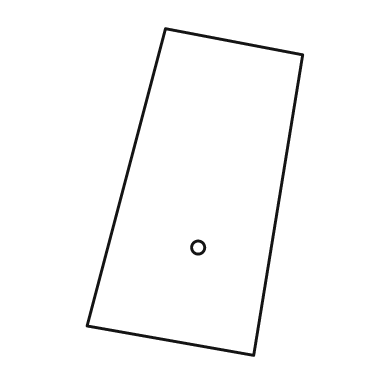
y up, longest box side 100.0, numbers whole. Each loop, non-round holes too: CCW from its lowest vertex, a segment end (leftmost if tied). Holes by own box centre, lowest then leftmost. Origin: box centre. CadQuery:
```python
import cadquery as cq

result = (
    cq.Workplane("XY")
    .moveTo(18.0, -50.0)
    .lineTo(33.0, 42.0)
    .lineTo(-9.0, 50.0)
    .lineTo(-33.0, -41.0)
    .close()
    .moveTo(1.0, -17.0)
    .circle(2.0)
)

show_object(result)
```